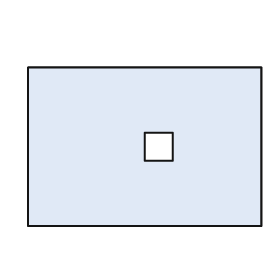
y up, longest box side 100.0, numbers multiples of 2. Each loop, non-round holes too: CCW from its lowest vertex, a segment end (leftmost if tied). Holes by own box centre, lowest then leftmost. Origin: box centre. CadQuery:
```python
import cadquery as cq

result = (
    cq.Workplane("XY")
    .moveTo(-50.0, -34.0)
    .lineTo(50.0, -34.0)
    .lineTo(50.0, 34.0)
    .lineTo(-50.0, 34.0)
    .close()
    .moveTo(0.0, -6.0)
    .lineTo(12.0, -6.0)
    .lineTo(12.0, 6.0)
    .lineTo(0.0, 6.0)
    .close()
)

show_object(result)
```